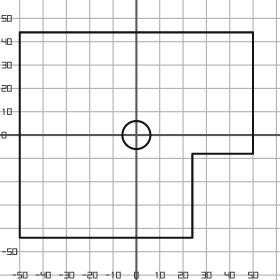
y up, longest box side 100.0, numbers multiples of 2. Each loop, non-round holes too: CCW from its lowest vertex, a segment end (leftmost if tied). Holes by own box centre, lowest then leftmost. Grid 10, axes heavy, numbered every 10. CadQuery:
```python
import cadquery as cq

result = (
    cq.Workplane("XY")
    .moveTo(-50.0, -44.0)
    .lineTo(24.0, -44.0)
    .lineTo(24.0, -8.0)
    .lineTo(50.0, -8.0)
    .lineTo(50.0, 44.0)
    .lineTo(-50.0, 44.0)
    .close()
    .moveTo(0.0, 0.0)
    .circle(6.0)
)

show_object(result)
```